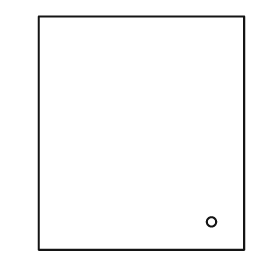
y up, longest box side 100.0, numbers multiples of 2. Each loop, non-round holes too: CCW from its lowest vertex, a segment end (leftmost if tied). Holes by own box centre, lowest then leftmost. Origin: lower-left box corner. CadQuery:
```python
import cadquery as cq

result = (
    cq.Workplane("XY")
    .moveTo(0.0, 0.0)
    .lineTo(88.0, 0.0)
    .lineTo(88.0, 100.0)
    .lineTo(0.0, 100.0)
    .close()
    .moveTo(74.0, 12.0)
    .circle(2.0)
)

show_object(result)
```